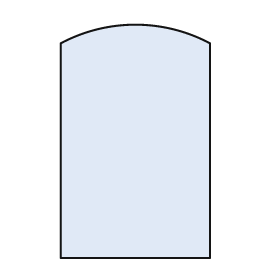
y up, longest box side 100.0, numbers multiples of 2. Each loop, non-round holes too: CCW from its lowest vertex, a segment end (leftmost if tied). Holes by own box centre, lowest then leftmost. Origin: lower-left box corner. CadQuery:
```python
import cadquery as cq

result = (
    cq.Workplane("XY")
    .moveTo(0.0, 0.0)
    .lineTo(64.0, 0.0)
    .lineTo(64.0, 92.0)
    .threePointArc((32.0, 100.0), (0.0, 92.0))
    .close()
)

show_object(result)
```